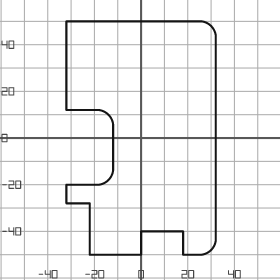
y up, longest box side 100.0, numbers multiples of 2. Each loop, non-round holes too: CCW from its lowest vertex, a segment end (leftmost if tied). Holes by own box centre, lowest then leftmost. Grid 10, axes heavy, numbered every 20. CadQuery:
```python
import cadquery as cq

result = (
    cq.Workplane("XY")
    .moveTo(-22.0, -50.0)
    .lineTo(0.0, -50.0)
    .lineTo(0.0, -40.0)
    .lineTo(18.0, -40.0)
    .lineTo(18.0, -50.0)
    .lineTo(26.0, -50.0)
    .threePointArc((30.0, -48.0), (32.0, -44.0))
    .lineTo(32.0, 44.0)
    .threePointArc((30.0, 48.0), (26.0, 50.0))
    .lineTo(-32.0, 50.0)
    .lineTo(-32.0, 12.0)
    .lineTo(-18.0, 12.0)
    .threePointArc((-14.0, 10.0), (-12.0, 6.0))
    .lineTo(-12.0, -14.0)
    .threePointArc((-14.0, -18.0), (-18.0, -20.0))
    .lineTo(-32.0, -20.0)
    .lineTo(-32.0, -28.0)
    .lineTo(-22.0, -28.0)
    .close()
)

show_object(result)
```